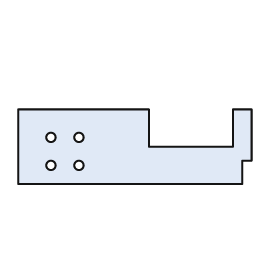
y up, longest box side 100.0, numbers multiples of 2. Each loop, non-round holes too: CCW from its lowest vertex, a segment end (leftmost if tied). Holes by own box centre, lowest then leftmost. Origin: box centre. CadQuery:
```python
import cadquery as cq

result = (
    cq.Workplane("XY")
    .moveTo(-50.0, -16.0)
    .lineTo(46.0, -16.0)
    .lineTo(46.0, -6.0)
    .lineTo(50.0, -6.0)
    .lineTo(50.0, 16.0)
    .lineTo(42.0, 16.0)
    .lineTo(42.0, 0.0)
    .lineTo(6.0, 0.0)
    .lineTo(6.0, 16.0)
    .lineTo(-50.0, 16.0)
    .close()
    .moveTo(-36.0, -8.0)
    .circle(2.0)
    .moveTo(-24.0, -8.0)
    .circle(2.0)
    .moveTo(-36.0, 4.0)
    .circle(2.0)
    .moveTo(-24.0, 4.0)
    .circle(2.0)
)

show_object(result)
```